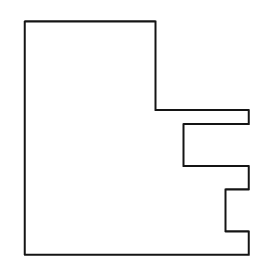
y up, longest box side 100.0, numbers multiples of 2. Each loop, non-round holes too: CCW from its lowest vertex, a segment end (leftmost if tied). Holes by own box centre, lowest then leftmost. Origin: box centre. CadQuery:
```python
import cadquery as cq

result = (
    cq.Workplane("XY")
    .moveTo(-48.0, -50.0)
    .lineTo(48.0, -50.0)
    .lineTo(48.0, -40.0)
    .lineTo(38.0, -40.0)
    .lineTo(38.0, -22.0)
    .lineTo(48.0, -22.0)
    .lineTo(48.0, -12.0)
    .lineTo(20.0, -12.0)
    .lineTo(20.0, 6.0)
    .lineTo(48.0, 6.0)
    .lineTo(48.0, 12.0)
    .lineTo(8.0, 12.0)
    .lineTo(8.0, 50.0)
    .lineTo(-48.0, 50.0)
    .close()
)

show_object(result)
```